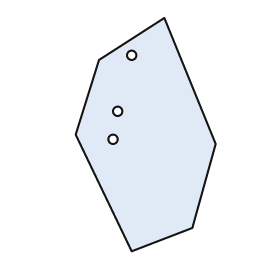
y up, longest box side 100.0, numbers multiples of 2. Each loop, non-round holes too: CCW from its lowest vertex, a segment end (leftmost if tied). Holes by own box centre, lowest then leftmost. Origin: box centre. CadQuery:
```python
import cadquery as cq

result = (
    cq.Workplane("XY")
    .moveTo(-6.0, -50.0)
    .lineTo(20.0, -40.0)
    .lineTo(30.0, -4.0)
    .lineTo(8.0, 50.0)
    .lineTo(-20.0, 32.0)
    .lineTo(-30.0, 0.0)
    .close()
    .moveTo(-14.0, -2.0)
    .circle(2.0)
    .moveTo(-12.0, 10.0)
    .circle(2.0)
    .moveTo(-6.0, 34.0)
    .circle(2.0)
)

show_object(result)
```